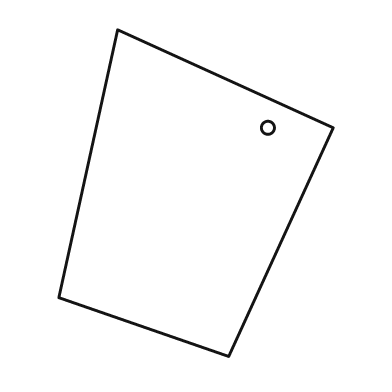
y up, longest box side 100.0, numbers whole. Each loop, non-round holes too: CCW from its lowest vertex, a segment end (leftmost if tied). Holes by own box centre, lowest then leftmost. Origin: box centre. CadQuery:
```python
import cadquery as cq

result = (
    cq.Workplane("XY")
    .moveTo(10.0, -50.0)
    .lineTo(42.0, 20.0)
    .lineTo(-24.0, 50.0)
    .lineTo(-42.0, -32.0)
    .close()
    .moveTo(22.0, 20.0)
    .circle(2.0)
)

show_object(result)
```